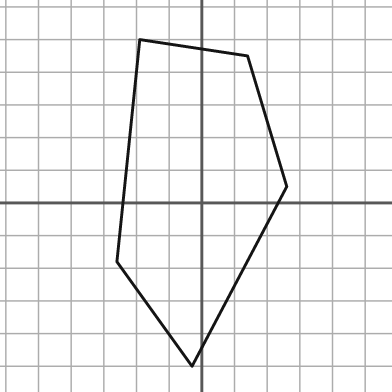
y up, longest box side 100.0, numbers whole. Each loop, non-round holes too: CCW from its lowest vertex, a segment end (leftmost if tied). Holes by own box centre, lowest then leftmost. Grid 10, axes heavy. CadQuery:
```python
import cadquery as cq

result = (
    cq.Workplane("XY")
    .moveTo(-3.0, -50.0)
    .lineTo(26.0, 5.0)
    .lineTo(14.0, 45.0)
    .lineTo(-19.0, 50.0)
    .lineTo(-26.0, -18.0)
    .close()
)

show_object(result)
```